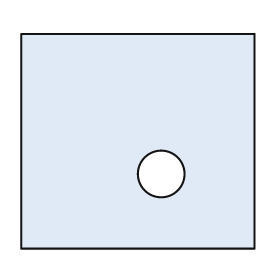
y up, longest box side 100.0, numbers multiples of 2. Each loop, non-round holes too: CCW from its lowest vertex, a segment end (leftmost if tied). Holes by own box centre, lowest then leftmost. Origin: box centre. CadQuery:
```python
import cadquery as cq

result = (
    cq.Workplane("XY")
    .moveTo(-50.0, -46.0)
    .lineTo(50.0, -46.0)
    .lineTo(50.0, 46.0)
    .lineTo(-50.0, 46.0)
    .close()
    .moveTo(10.0, -14.0)
    .circle(10.0)
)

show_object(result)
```